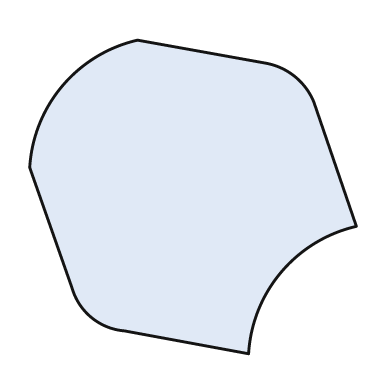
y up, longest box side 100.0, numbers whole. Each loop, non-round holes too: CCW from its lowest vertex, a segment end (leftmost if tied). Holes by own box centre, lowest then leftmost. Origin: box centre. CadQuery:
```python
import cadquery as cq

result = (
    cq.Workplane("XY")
    .moveTo(17.0, -48.0)
    .threePointArc((27.0, -23.0), (50.0, -9.0))
    .lineTo(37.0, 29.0)
    .threePointArc((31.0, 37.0), (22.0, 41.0))
    .lineTo(-17.0, 48.0)
    .threePointArc((-40.0, 34.0), (-50.0, 9.0))
    .lineTo(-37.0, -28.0)
    .threePointArc((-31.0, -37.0), (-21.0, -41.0))
    .close()
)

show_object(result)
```